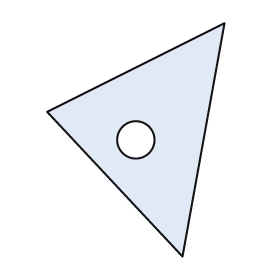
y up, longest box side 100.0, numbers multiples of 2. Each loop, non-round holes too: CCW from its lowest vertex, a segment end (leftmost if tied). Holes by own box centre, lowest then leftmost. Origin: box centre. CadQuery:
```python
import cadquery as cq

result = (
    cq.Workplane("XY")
    .moveTo(20.0, -50.0)
    .lineTo(38.0, 50.0)
    .lineTo(-38.0, 12.0)
    .close()
    .moveTo(0.0, 0.0)
    .circle(8.0)
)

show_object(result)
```